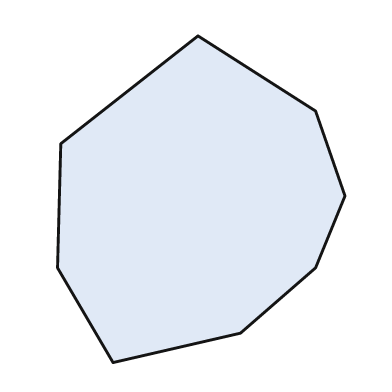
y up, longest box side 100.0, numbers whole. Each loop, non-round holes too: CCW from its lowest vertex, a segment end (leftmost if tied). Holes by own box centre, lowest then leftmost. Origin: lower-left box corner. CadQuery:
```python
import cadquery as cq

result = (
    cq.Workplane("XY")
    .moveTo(17.0, 0.0)
    .lineTo(56.0, 9.0)
    .lineTo(79.0, 29.0)
    .lineTo(88.0, 51.0)
    .lineTo(79.0, 77.0)
    .lineTo(43.0, 100.0)
    .lineTo(1.0, 67.0)
    .lineTo(0.0, 29.0)
    .close()
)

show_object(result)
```